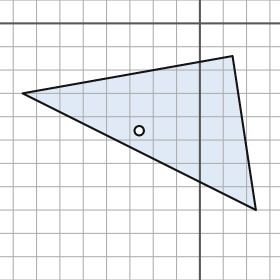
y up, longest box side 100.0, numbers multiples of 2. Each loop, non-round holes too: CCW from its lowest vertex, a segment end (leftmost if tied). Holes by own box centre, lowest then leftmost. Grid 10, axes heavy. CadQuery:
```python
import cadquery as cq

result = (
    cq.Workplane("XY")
    .moveTo(24.0, -80.0)
    .lineTo(14.0, -14.0)
    .lineTo(-76.0, -30.0)
    .close()
    .moveTo(-26.0, -46.0)
    .circle(2.0)
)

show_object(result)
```